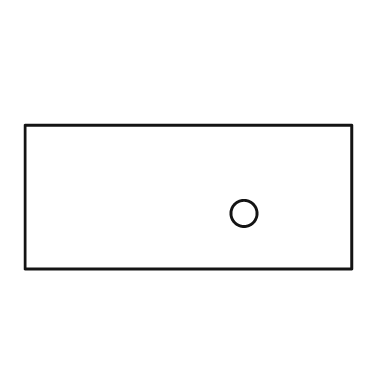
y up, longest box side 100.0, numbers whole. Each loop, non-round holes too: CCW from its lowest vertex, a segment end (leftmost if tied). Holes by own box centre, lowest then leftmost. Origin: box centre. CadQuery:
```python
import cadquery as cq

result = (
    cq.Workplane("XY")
    .moveTo(-50.0, -22.0)
    .lineTo(50.0, -22.0)
    .lineTo(50.0, 22.0)
    .lineTo(-50.0, 22.0)
    .close()
    .moveTo(17.0, -5.0)
    .circle(4.0)
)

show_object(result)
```